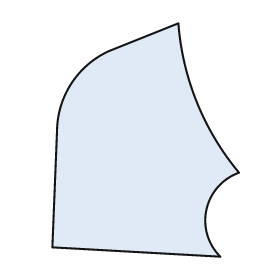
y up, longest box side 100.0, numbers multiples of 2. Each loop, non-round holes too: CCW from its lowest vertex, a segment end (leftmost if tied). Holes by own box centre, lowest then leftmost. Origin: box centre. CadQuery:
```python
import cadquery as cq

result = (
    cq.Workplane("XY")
    .moveTo(32.0, -50.0)
    .threePointArc((26.0, -30.0), (40.0, -14.0))
    .threePointArc((22.0, 16.0), (14.0, 50.0))
    .lineTo(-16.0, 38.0)
    .threePointArc((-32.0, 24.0), (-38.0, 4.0))
    .lineTo(-40.0, -46.0)
    .close()
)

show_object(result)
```